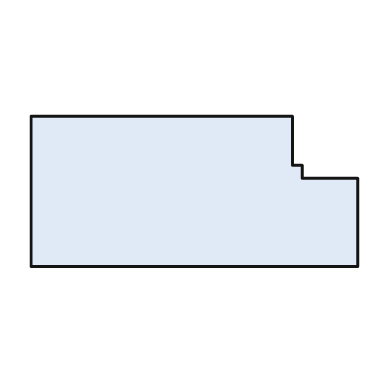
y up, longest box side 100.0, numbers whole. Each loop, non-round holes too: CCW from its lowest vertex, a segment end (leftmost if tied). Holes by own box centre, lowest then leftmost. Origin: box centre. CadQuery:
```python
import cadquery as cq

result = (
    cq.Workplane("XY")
    .moveTo(-50.0, -23.0)
    .lineTo(50.0, -23.0)
    .lineTo(50.0, 4.0)
    .lineTo(33.0, 4.0)
    .lineTo(33.0, 8.0)
    .lineTo(30.0, 8.0)
    .lineTo(30.0, 23.0)
    .lineTo(-50.0, 23.0)
    .close()
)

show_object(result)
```